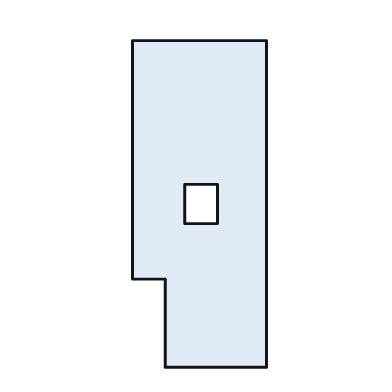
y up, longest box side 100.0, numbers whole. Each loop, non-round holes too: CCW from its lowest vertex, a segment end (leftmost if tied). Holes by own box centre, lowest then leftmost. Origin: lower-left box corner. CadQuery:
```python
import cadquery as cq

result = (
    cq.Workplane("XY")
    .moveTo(10.0, 0.0)
    .lineTo(41.0, 0.0)
    .lineTo(41.0, 100.0)
    .lineTo(0.0, 100.0)
    .lineTo(0.0, 27.0)
    .lineTo(10.0, 27.0)
    .close()
    .moveTo(16.0, 44.0)
    .lineTo(26.0, 44.0)
    .lineTo(26.0, 56.0)
    .lineTo(16.0, 56.0)
    .close()
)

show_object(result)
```